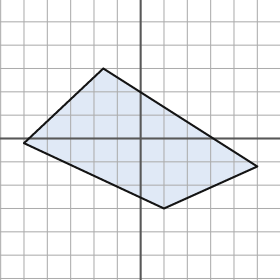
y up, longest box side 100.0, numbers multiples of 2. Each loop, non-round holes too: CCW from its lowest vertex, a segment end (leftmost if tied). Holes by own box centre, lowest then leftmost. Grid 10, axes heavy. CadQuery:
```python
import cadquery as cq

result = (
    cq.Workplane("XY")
    .moveTo(10.0, -30.0)
    .lineTo(50.0, -12.0)
    .lineTo(-16.0, 30.0)
    .lineTo(-50.0, -2.0)
    .close()
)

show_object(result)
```